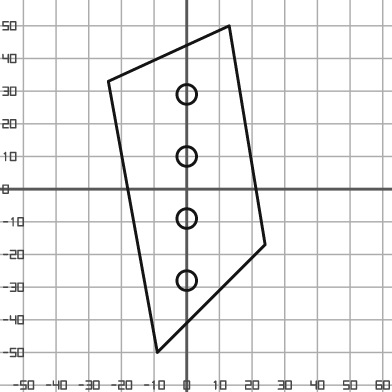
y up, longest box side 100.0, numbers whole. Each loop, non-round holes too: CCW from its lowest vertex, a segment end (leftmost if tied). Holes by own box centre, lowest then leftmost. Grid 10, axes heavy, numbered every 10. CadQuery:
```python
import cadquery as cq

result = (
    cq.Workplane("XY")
    .moveTo(-9.0, -50.0)
    .lineTo(24.0, -17.0)
    .lineTo(13.0, 50.0)
    .lineTo(-24.0, 33.0)
    .close()
    .moveTo(0.0, -28.0)
    .circle(3.0)
    .moveTo(0.0, -9.0)
    .circle(3.0)
    .moveTo(0.0, 10.0)
    .circle(3.0)
    .moveTo(0.0, 29.0)
    .circle(3.0)
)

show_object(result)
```